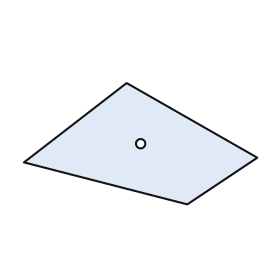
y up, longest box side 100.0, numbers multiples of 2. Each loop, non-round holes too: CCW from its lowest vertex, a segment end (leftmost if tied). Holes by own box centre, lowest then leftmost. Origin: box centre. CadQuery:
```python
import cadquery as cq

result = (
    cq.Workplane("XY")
    .moveTo(20.0, -26.0)
    .lineTo(50.0, -6.0)
    .lineTo(-6.0, 26.0)
    .lineTo(-50.0, -8.0)
    .close()
    .moveTo(0.0, 0.0)
    .circle(2.0)
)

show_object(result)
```